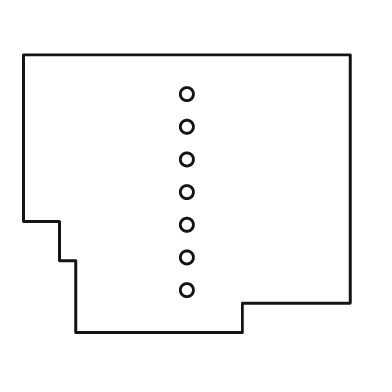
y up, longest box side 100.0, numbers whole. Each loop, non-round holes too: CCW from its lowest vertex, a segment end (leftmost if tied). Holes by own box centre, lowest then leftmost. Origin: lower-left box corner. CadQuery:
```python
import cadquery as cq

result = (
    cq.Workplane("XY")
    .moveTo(16.0, 0.0)
    .lineTo(67.0, 0.0)
    .lineTo(67.0, 9.0)
    .lineTo(100.0, 9.0)
    .lineTo(100.0, 85.0)
    .lineTo(0.0, 85.0)
    .lineTo(0.0, 34.0)
    .lineTo(11.0, 34.0)
    .lineTo(11.0, 22.0)
    .lineTo(16.0, 22.0)
    .close()
    .moveTo(50.0, 13.0)
    .circle(2.0)
    .moveTo(50.0, 23.0)
    .circle(2.0)
    .moveTo(50.0, 33.0)
    .circle(2.0)
    .moveTo(50.0, 43.0)
    .circle(2.0)
    .moveTo(50.0, 53.0)
    .circle(2.0)
    .moveTo(50.0, 63.0)
    .circle(2.0)
    .moveTo(50.0, 73.0)
    .circle(2.0)
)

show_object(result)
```